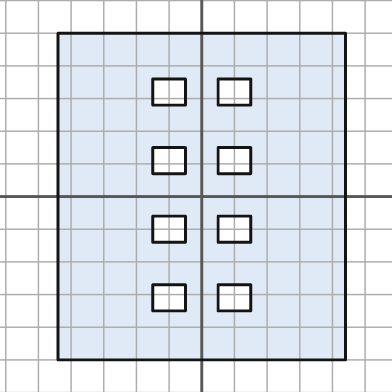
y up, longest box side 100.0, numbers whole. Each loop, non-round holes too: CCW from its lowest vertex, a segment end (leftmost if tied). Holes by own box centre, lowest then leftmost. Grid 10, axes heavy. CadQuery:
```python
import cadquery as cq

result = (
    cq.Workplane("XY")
    .moveTo(-44.0, -50.0)
    .lineTo(44.0, -50.0)
    .lineTo(44.0, 50.0)
    .lineTo(-44.0, 50.0)
    .close()
    .moveTo(-15.0, -35.0)
    .lineTo(-5.0, -35.0)
    .lineTo(-5.0, -27.0)
    .lineTo(-15.0, -27.0)
    .close()
    .moveTo(5.0, -35.0)
    .lineTo(15.0, -35.0)
    .lineTo(15.0, -27.0)
    .lineTo(5.0, -27.0)
    .close()
    .moveTo(-15.0, -14.0)
    .lineTo(-5.0, -14.0)
    .lineTo(-5.0, -6.0)
    .lineTo(-15.0, -6.0)
    .close()
    .moveTo(5.0, -14.0)
    .lineTo(15.0, -14.0)
    .lineTo(15.0, -6.0)
    .lineTo(5.0, -6.0)
    .close()
    .moveTo(-15.0, 7.0)
    .lineTo(-5.0, 7.0)
    .lineTo(-5.0, 15.0)
    .lineTo(-15.0, 15.0)
    .close()
    .moveTo(5.0, 7.0)
    .lineTo(15.0, 7.0)
    .lineTo(15.0, 15.0)
    .lineTo(5.0, 15.0)
    .close()
    .moveTo(-15.0, 28.0)
    .lineTo(-5.0, 28.0)
    .lineTo(-5.0, 36.0)
    .lineTo(-15.0, 36.0)
    .close()
    .moveTo(5.0, 28.0)
    .lineTo(15.0, 28.0)
    .lineTo(15.0, 36.0)
    .lineTo(5.0, 36.0)
    .close()
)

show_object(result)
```